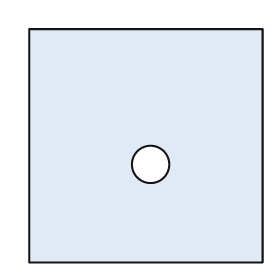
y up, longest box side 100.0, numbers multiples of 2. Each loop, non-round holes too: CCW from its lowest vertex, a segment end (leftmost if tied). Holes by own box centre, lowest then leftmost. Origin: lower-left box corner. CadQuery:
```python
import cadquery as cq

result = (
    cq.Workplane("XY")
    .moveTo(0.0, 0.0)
    .lineTo(100.0, 0.0)
    .lineTo(100.0, 100.0)
    .lineTo(0.0, 100.0)
    .close()
    .moveTo(52.0, 42.0)
    .circle(8.0)
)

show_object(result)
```